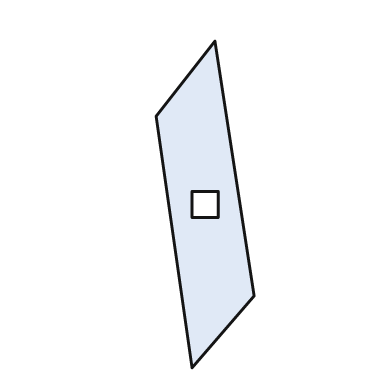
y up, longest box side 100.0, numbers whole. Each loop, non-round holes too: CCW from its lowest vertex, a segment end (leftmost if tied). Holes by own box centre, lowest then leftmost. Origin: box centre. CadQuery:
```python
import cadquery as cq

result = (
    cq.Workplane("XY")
    .moveTo(-4.0, -50.0)
    .lineTo(15.0, -28.0)
    .lineTo(3.0, 50.0)
    .lineTo(-15.0, 27.0)
    .close()
    .moveTo(-4.0, -4.0)
    .lineTo(4.0, -4.0)
    .lineTo(4.0, 4.0)
    .lineTo(-4.0, 4.0)
    .close()
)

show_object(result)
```